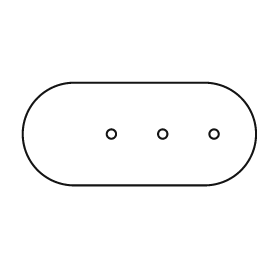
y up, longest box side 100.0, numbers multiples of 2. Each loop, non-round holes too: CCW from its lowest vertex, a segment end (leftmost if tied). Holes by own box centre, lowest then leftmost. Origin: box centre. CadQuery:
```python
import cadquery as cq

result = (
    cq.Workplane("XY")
    .moveTo(-28.0, -22.0)
    .lineTo(28.0, -22.0)
    .threePointArc((50.0, 0.0), (28.0, 22.0))
    .lineTo(-28.0, 22.0)
    .threePointArc((-50.0, 0.0), (-28.0, -22.0))
    .close()
    .moveTo(-12.0, 0.0)
    .circle(2.0)
    .moveTo(10.0, 0.0)
    .circle(2.0)
    .moveTo(32.0, 0.0)
    .circle(2.0)
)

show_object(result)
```